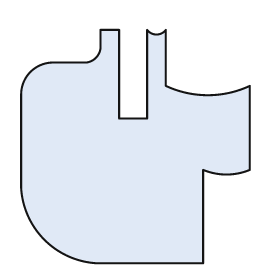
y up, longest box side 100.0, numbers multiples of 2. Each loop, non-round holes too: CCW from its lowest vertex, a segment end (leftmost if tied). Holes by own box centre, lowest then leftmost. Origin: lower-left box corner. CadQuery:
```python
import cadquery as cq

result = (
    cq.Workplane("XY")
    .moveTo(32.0, 0.0)
    .lineTo(78.0, 0.0)
    .lineTo(78.0, 40.0)
    .threePointArc((88.0, 38.0), (98.0, 40.0))
    .lineTo(98.0, 76.0)
    .threePointArc((80.0, 72.0), (62.0, 76.0))
    .lineTo(62.0, 100.0)
    .threePointArc((58.0, 98.0), (54.0, 100.0))
    .lineTo(54.0, 62.0)
    .lineTo(42.0, 62.0)
    .lineTo(42.0, 100.0)
    .lineTo(34.0, 100.0)
    .lineTo(34.0, 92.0)
    .threePointArc((32.0, 88.0), (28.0, 86.0))
    .lineTo(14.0, 86.0)
    .threePointArc((4.0, 82.0), (0.0, 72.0))
    .lineTo(0.0, 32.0)
    .threePointArc((10.0, 10.0), (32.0, 0.0))
    .close()
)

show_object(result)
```